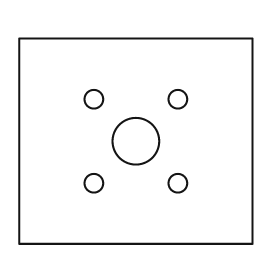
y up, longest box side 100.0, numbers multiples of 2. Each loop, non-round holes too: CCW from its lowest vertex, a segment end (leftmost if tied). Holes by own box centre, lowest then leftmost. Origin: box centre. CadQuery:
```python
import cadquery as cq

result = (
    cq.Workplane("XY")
    .moveTo(-50.0, -44.0)
    .lineTo(50.0, -44.0)
    .lineTo(50.0, 44.0)
    .lineTo(-50.0, 44.0)
    .close()
    .moveTo(-18.0, -18.0)
    .circle(4.0)
    .moveTo(18.0, -18.0)
    .circle(4.0)
    .moveTo(0.0, 0.0)
    .circle(10.0)
    .moveTo(-18.0, 18.0)
    .circle(4.0)
    .moveTo(18.0, 18.0)
    .circle(4.0)
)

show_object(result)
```